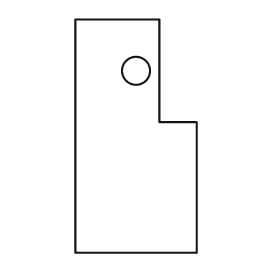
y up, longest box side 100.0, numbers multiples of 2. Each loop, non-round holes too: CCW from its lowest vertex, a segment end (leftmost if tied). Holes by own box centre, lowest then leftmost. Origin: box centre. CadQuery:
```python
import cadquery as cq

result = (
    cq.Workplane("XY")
    .moveTo(-26.0, -50.0)
    .lineTo(26.0, -50.0)
    .lineTo(26.0, 6.0)
    .lineTo(10.0, 6.0)
    .lineTo(10.0, 50.0)
    .lineTo(-26.0, 50.0)
    .close()
    .moveTo(0.0, 28.0)
    .circle(6.0)
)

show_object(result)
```